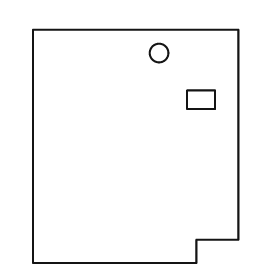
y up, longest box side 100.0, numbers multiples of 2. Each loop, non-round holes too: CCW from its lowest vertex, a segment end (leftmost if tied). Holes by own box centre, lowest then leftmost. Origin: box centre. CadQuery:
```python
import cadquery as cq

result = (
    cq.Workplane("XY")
    .moveTo(-44.0, -50.0)
    .lineTo(26.0, -50.0)
    .lineTo(26.0, -40.0)
    .lineTo(44.0, -40.0)
    .lineTo(44.0, 50.0)
    .lineTo(-44.0, 50.0)
    .close()
    .moveTo(22.0, 16.0)
    .lineTo(34.0, 16.0)
    .lineTo(34.0, 24.0)
    .lineTo(22.0, 24.0)
    .close()
    .moveTo(10.0, 40.0)
    .circle(4.0)
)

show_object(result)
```